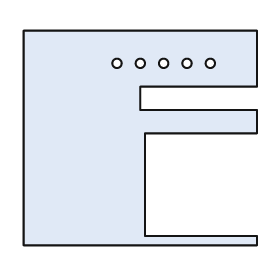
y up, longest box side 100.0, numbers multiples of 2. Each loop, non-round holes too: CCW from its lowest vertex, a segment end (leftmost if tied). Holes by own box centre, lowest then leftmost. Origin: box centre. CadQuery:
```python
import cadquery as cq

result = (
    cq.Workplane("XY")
    .moveTo(-50.0, -46.0)
    .lineTo(50.0, -46.0)
    .lineTo(50.0, -42.0)
    .lineTo(2.0, -42.0)
    .lineTo(2.0, 2.0)
    .lineTo(50.0, 2.0)
    .lineTo(50.0, 12.0)
    .lineTo(0.0, 12.0)
    .lineTo(0.0, 22.0)
    .lineTo(50.0, 22.0)
    .lineTo(50.0, 46.0)
    .lineTo(-50.0, 46.0)
    .close()
    .moveTo(-10.0, 32.0)
    .circle(2.0)
    .moveTo(0.0, 32.0)
    .circle(2.0)
    .moveTo(10.0, 32.0)
    .circle(2.0)
    .moveTo(20.0, 32.0)
    .circle(2.0)
    .moveTo(30.0, 32.0)
    .circle(2.0)
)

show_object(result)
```